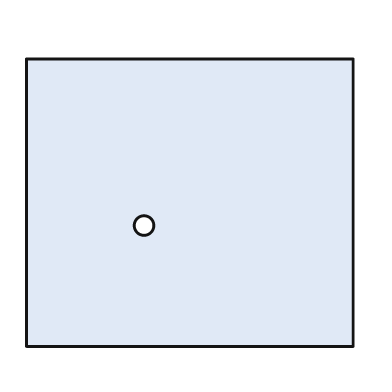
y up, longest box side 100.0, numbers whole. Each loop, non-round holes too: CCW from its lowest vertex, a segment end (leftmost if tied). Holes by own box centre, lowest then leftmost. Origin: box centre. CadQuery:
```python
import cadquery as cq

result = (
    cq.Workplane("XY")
    .moveTo(-50.0, -44.0)
    .lineTo(50.0, -44.0)
    .lineTo(50.0, 44.0)
    .lineTo(-50.0, 44.0)
    .close()
    .moveTo(-14.0, -7.0)
    .circle(3.0)
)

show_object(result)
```